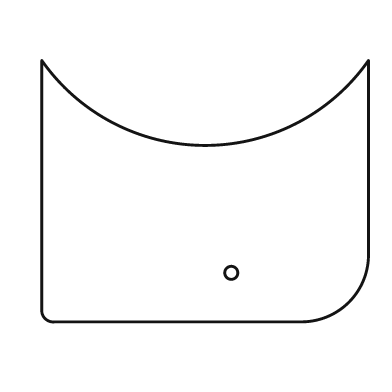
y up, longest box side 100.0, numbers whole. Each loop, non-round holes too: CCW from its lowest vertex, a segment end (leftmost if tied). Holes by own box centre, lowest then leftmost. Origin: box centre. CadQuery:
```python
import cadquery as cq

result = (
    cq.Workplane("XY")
    .moveTo(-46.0, -40.0)
    .lineTo(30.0, -40.0)
    .threePointArc((44.0, -34.0), (50.0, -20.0))
    .lineTo(50.0, 40.0)
    .threePointArc((0.0, 14.0), (-50.0, 40.0))
    .lineTo(-50.0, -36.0)
    .threePointArc((-49.0, -39.0), (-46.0, -40.0))
    .close()
    .moveTo(8.0, -25.0)
    .circle(2.0)
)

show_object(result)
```